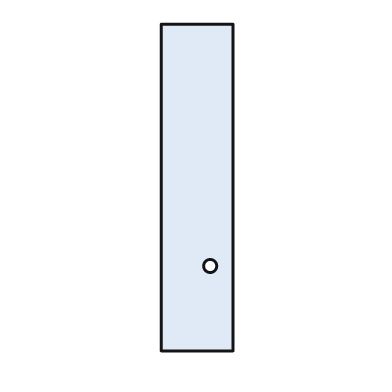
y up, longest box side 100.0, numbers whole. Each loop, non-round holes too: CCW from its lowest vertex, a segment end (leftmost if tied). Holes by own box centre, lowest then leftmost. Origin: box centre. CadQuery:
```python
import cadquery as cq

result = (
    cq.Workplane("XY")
    .moveTo(-11.0, -50.0)
    .lineTo(11.0, -50.0)
    .lineTo(11.0, 50.0)
    .lineTo(-11.0, 50.0)
    .close()
    .moveTo(4.0, -24.0)
    .circle(2.0)
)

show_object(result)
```